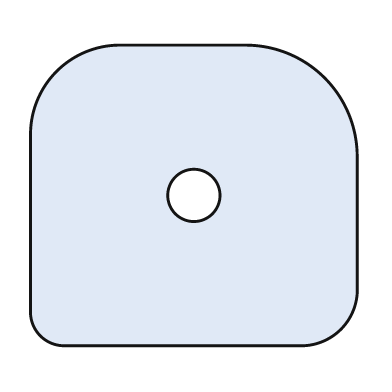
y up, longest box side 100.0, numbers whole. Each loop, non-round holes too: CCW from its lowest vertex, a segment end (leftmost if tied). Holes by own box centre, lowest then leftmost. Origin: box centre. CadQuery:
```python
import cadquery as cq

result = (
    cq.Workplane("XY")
    .moveTo(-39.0, -46.0)
    .lineTo(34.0, -46.0)
    .threePointArc((45.0, -41.0), (50.0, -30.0))
    .lineTo(50.0, 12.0)
    .threePointArc((40.0, 36.0), (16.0, 46.0))
    .lineTo(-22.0, 46.0)
    .threePointArc((-42.0, 38.0), (-50.0, 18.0))
    .lineTo(-50.0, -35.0)
    .threePointArc((-47.0, -43.0), (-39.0, -46.0))
    .close()
    .moveTo(0.0, 0.0)
    .circle(8.0)
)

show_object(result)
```